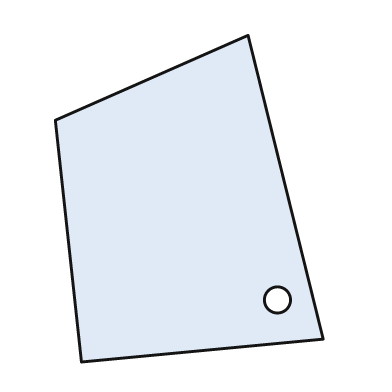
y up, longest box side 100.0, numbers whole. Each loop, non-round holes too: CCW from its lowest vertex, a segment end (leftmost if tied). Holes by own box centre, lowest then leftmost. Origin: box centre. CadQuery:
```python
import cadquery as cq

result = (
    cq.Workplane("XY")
    .moveTo(-33.0, -50.0)
    .lineTo(41.0, -43.0)
    .lineTo(18.0, 50.0)
    .lineTo(-41.0, 24.0)
    .close()
    .moveTo(27.0, -31.0)
    .circle(4.0)
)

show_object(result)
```